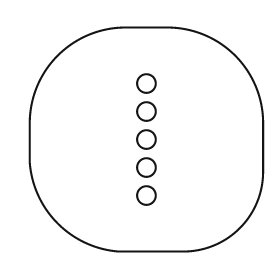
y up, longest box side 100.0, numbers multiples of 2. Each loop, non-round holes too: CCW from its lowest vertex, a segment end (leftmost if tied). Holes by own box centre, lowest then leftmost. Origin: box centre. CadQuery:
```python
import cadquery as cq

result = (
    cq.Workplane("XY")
    .moveTo(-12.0, -48.0)
    .lineTo(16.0, -48.0)
    .threePointArc((40.0, -38.0), (50.0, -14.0))
    .lineTo(50.0, 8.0)
    .threePointArc((38.0, 36.0), (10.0, 48.0))
    .lineTo(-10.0, 48.0)
    .threePointArc((-38.0, 36.0), (-50.0, 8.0))
    .lineTo(-50.0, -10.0)
    .threePointArc((-38.0, -36.0), (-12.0, -48.0))
    .close()
    .moveTo(0.0, -24.0)
    .circle(4.0)
    .moveTo(0.0, -12.0)
    .circle(4.0)
    .moveTo(0.0, 0.0)
    .circle(4.0)
    .moveTo(0.0, 12.0)
    .circle(4.0)
    .moveTo(0.0, 24.0)
    .circle(4.0)
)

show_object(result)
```